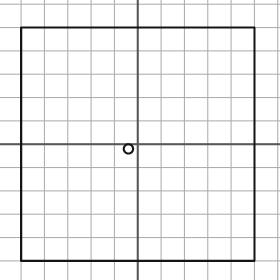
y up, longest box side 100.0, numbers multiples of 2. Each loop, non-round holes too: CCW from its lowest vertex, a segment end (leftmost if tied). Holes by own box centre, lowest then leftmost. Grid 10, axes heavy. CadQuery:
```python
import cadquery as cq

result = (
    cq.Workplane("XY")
    .moveTo(-50.0, -50.0)
    .lineTo(50.0, -50.0)
    .lineTo(50.0, 50.0)
    .lineTo(-50.0, 50.0)
    .close()
    .moveTo(-4.0, -2.0)
    .circle(2.0)
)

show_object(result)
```